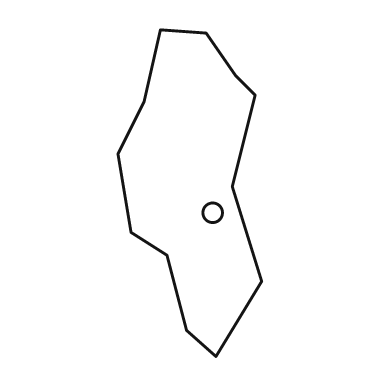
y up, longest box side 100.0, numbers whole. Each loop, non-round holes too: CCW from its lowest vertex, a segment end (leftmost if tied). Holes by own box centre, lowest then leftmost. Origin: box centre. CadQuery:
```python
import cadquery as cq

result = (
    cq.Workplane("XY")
    .moveTo(8.0, -50.0)
    .lineTo(22.0, -27.0)
    .lineTo(13.0, 2.0)
    .lineTo(20.0, 30.0)
    .lineTo(14.0, 36.0)
    .lineTo(5.0, 49.0)
    .lineTo(-9.0, 50.0)
    .lineTo(-14.0, 28.0)
    .lineTo(-22.0, 12.0)
    .lineTo(-18.0, -12.0)
    .lineTo(-7.0, -19.0)
    .lineTo(-1.0, -42.0)
    .close()
    .moveTo(7.0, -6.0)
    .circle(3.0)
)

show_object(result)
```